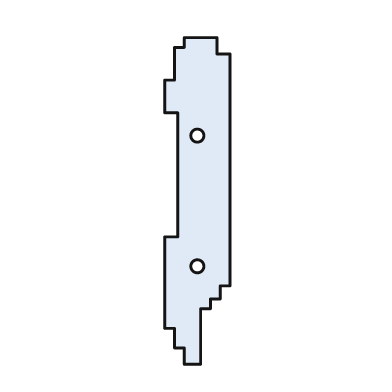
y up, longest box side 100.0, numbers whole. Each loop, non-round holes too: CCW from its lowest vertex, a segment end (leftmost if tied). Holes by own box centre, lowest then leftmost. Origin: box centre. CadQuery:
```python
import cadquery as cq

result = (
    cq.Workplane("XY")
    .moveTo(-4.0, -50.0)
    .lineTo(1.0, -50.0)
    .lineTo(1.0, -33.0)
    .lineTo(4.0, -33.0)
    .lineTo(4.0, -30.0)
    .lineTo(7.0, -30.0)
    .lineTo(7.0, -26.0)
    .lineTo(10.0, -26.0)
    .lineTo(10.0, 45.0)
    .lineTo(6.0, 45.0)
    .lineTo(6.0, 50.0)
    .lineTo(-4.0, 50.0)
    .lineTo(-4.0, 47.0)
    .lineTo(-7.0, 47.0)
    .lineTo(-7.0, 37.0)
    .lineTo(-10.0, 37.0)
    .lineTo(-10.0, 27.0)
    .lineTo(-6.0, 27.0)
    .lineTo(-6.0, -11.0)
    .lineTo(-10.0, -11.0)
    .lineTo(-10.0, -39.0)
    .lineTo(-7.0, -39.0)
    .lineTo(-7.0, -45.0)
    .lineTo(-4.0, -45.0)
    .close()
    .moveTo(0.0, -20.0)
    .circle(2.0)
    .moveTo(0.0, 20.0)
    .circle(2.0)
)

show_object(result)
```